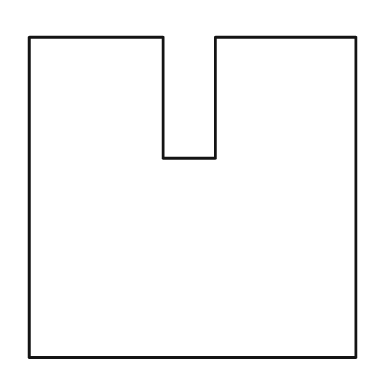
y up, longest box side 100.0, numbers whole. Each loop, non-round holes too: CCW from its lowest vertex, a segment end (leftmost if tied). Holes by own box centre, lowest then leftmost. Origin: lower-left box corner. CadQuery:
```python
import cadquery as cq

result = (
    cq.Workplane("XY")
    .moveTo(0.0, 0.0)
    .lineTo(100.0, 0.0)
    .lineTo(100.0, 98.0)
    .lineTo(57.0, 98.0)
    .lineTo(57.0, 61.0)
    .lineTo(41.0, 61.0)
    .lineTo(41.0, 98.0)
    .lineTo(0.0, 98.0)
    .close()
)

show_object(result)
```